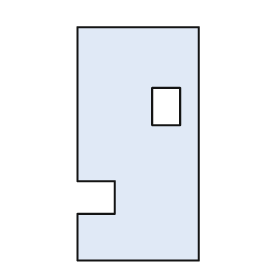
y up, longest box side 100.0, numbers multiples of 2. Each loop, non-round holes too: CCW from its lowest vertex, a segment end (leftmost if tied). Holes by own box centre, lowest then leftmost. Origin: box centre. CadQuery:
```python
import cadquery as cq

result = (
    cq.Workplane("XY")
    .moveTo(-26.0, -50.0)
    .lineTo(26.0, -50.0)
    .lineTo(26.0, 50.0)
    .lineTo(-26.0, 50.0)
    .lineTo(-26.0, -16.0)
    .lineTo(-10.0, -16.0)
    .lineTo(-10.0, -30.0)
    .lineTo(-26.0, -30.0)
    .close()
    .moveTo(6.0, 8.0)
    .lineTo(18.0, 8.0)
    .lineTo(18.0, 24.0)
    .lineTo(6.0, 24.0)
    .close()
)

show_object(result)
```